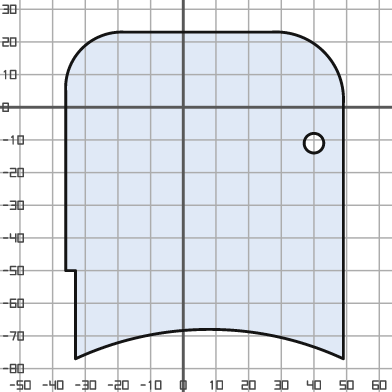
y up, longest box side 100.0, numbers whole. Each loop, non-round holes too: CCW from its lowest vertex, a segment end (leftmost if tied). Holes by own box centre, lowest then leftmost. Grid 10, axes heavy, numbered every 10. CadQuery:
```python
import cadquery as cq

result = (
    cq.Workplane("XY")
    .moveTo(-33.0, -77.0)
    .threePointArc((8.0, -68.0), (49.0, -77.0))
    .lineTo(49.0, 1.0)
    .threePointArc((43.0, 17.0), (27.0, 23.0))
    .lineTo(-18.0, 23.0)
    .threePointArc((-31.0, 18.0), (-36.0, 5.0))
    .lineTo(-36.0, -50.0)
    .lineTo(-33.0, -50.0)
    .close()
    .moveTo(40.0, -11.0)
    .circle(3.0)
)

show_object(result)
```